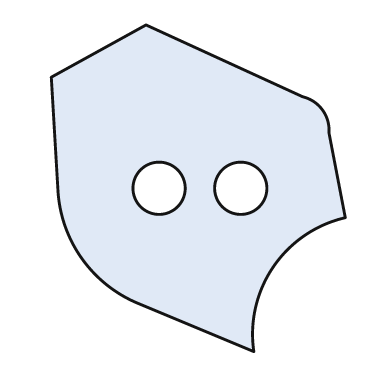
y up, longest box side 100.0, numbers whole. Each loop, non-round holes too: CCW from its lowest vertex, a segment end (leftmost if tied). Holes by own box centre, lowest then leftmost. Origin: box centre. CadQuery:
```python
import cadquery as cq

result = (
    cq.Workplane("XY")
    .moveTo(17.0, -50.0)
    .threePointArc((23.0, -24.0), (45.0, -9.0))
    .lineTo(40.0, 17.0)
    .threePointArc((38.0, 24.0), (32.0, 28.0))
    .lineTo(-16.0, 50.0)
    .lineTo(-45.0, 34.0)
    .lineTo(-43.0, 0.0)
    .threePointArc((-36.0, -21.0), (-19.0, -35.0))
    .close()
    .moveTo(-12.0, 0.0)
    .circle(8.0)
    .moveTo(13.0, 0.0)
    .circle(8.0)
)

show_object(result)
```